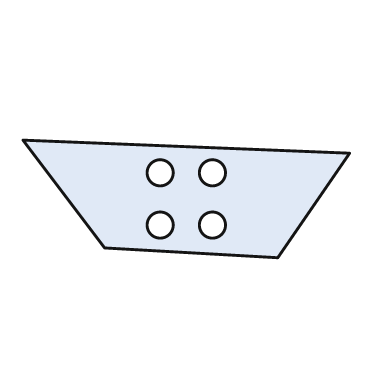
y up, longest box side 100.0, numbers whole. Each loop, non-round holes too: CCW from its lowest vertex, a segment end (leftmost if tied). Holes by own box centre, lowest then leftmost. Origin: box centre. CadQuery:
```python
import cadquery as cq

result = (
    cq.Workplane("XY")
    .moveTo(28.0, -18.0)
    .lineTo(50.0, 14.0)
    .lineTo(-50.0, 18.0)
    .lineTo(-25.0, -15.0)
    .close()
    .moveTo(-8.0, -8.0)
    .circle(4.0)
    .moveTo(8.0, -8.0)
    .circle(4.0)
    .moveTo(-8.0, 8.0)
    .circle(4.0)
    .moveTo(8.0, 8.0)
    .circle(4.0)
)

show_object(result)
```